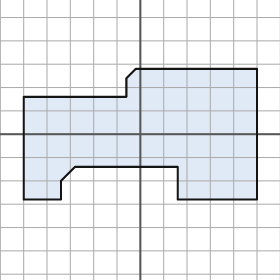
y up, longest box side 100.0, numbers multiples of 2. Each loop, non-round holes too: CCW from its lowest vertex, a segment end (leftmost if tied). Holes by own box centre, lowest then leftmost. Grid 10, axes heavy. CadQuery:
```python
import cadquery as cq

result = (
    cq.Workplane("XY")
    .moveTo(-50.0, -28.0)
    .lineTo(-34.0, -28.0)
    .lineTo(-34.0, -20.0)
    .lineTo(-28.0, -14.0)
    .lineTo(16.0, -14.0)
    .lineTo(16.0, -28.0)
    .lineTo(50.0, -28.0)
    .lineTo(50.0, 28.0)
    .lineTo(-2.0, 28.0)
    .lineTo(-6.0, 24.0)
    .lineTo(-6.0, 16.0)
    .lineTo(-50.0, 16.0)
    .close()
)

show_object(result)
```